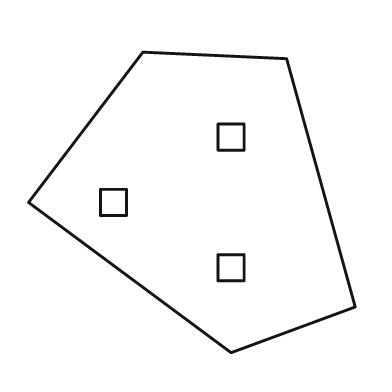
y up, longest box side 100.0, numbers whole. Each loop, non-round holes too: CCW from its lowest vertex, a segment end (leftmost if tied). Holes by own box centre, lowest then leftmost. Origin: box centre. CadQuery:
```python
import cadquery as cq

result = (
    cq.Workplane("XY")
    .moveTo(12.0, -46.0)
    .lineTo(50.0, -32.0)
    .lineTo(29.0, 44.0)
    .lineTo(-15.0, 46.0)
    .lineTo(-50.0, 0.0)
    .close()
    .moveTo(8.0, -24.0)
    .lineTo(16.0, -24.0)
    .lineTo(16.0, -16.0)
    .lineTo(8.0, -16.0)
    .close()
    .moveTo(-28.0, -4.0)
    .lineTo(-20.0, -4.0)
    .lineTo(-20.0, 4.0)
    .lineTo(-28.0, 4.0)
    .close()
    .moveTo(8.0, 16.0)
    .lineTo(16.0, 16.0)
    .lineTo(16.0, 24.0)
    .lineTo(8.0, 24.0)
    .close()
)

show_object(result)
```